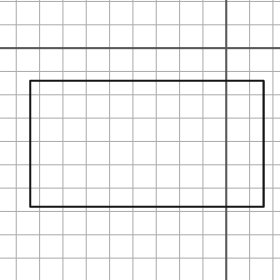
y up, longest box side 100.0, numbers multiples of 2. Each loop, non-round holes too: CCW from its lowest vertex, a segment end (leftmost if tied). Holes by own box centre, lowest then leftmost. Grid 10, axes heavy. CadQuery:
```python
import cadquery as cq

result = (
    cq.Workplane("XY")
    .moveTo(-84.0, -68.0)
    .lineTo(16.0, -68.0)
    .lineTo(16.0, -14.0)
    .lineTo(-84.0, -14.0)
    .close()
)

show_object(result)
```